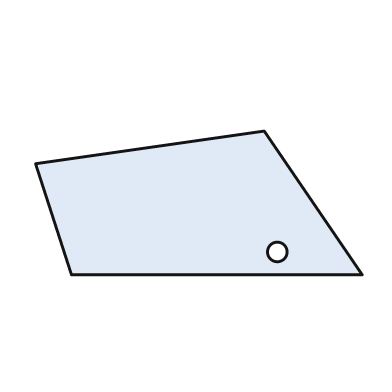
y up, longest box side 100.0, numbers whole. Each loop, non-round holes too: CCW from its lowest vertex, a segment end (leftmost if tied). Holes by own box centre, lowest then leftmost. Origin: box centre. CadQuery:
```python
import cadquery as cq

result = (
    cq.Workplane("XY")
    .moveTo(-39.0, -22.0)
    .lineTo(50.0, -22.0)
    .lineTo(20.0, 22.0)
    .lineTo(-50.0, 12.0)
    .close()
    .moveTo(24.0, -15.0)
    .circle(3.0)
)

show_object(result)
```